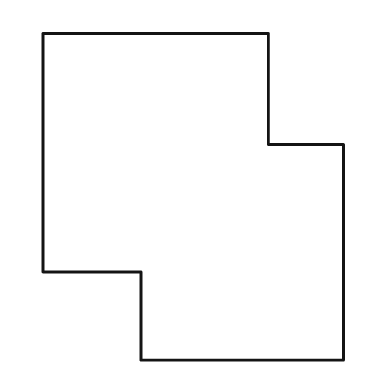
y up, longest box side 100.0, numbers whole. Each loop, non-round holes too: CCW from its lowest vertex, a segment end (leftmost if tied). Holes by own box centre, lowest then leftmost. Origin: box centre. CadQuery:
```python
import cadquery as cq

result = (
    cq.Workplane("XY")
    .moveTo(-16.0, -50.0)
    .lineTo(46.0, -50.0)
    .lineTo(46.0, 16.0)
    .lineTo(23.0, 16.0)
    .lineTo(23.0, 50.0)
    .lineTo(-46.0, 50.0)
    .lineTo(-46.0, -23.0)
    .lineTo(-16.0, -23.0)
    .close()
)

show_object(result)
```